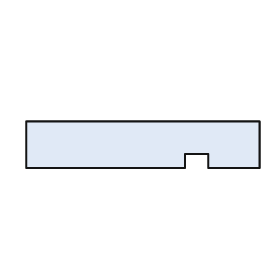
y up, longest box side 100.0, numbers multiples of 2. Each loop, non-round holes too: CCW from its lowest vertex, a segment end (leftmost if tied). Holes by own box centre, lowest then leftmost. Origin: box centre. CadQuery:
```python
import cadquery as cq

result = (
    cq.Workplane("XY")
    .moveTo(-50.0, -10.0)
    .lineTo(18.0, -10.0)
    .lineTo(18.0, -4.0)
    .lineTo(28.0, -4.0)
    .lineTo(28.0, -10.0)
    .lineTo(50.0, -10.0)
    .lineTo(50.0, 10.0)
    .lineTo(-50.0, 10.0)
    .close()
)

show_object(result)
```